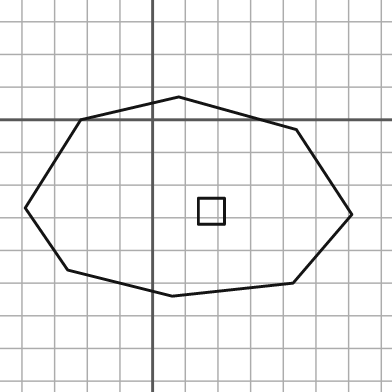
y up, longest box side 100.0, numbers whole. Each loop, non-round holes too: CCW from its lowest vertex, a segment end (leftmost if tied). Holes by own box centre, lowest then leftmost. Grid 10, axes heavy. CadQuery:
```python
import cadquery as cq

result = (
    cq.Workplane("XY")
    .moveTo(6.0, -54.0)
    .lineTo(43.0, -50.0)
    .lineTo(61.0, -29.0)
    .lineTo(44.0, -3.0)
    .lineTo(8.0, 7.0)
    .lineTo(-22.0, 0.0)
    .lineTo(-39.0, -27.0)
    .lineTo(-26.0, -46.0)
    .close()
    .moveTo(14.0, -32.0)
    .lineTo(22.0, -32.0)
    .lineTo(22.0, -24.0)
    .lineTo(14.0, -24.0)
    .close()
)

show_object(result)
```